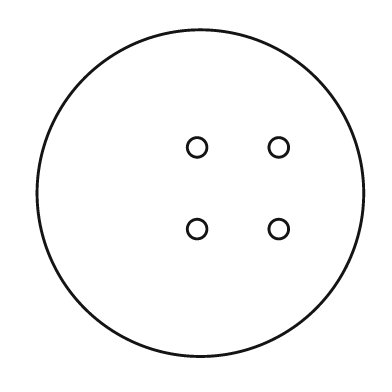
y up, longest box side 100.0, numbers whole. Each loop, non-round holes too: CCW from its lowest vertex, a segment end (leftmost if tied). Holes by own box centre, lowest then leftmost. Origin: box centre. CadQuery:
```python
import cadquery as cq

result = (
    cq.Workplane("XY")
    .moveTo(0.0, 0.0)
    .circle(50.0)
    .moveTo(-1.0, -11.0)
    .circle(3.0)
    .moveTo(24.0, -11.0)
    .circle(3.0)
    .moveTo(-1.0, 14.0)
    .circle(3.0)
    .moveTo(24.0, 14.0)
    .circle(3.0)
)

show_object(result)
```